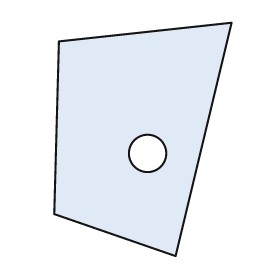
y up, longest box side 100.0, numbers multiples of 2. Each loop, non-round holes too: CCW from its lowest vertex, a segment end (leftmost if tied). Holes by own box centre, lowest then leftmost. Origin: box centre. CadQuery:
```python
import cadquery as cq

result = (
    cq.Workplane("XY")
    .moveTo(14.0, -50.0)
    .lineTo(38.0, 50.0)
    .lineTo(-36.0, 42.0)
    .lineTo(-38.0, -32.0)
    .close()
    .moveTo(2.0, -6.0)
    .circle(8.0)
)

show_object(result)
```